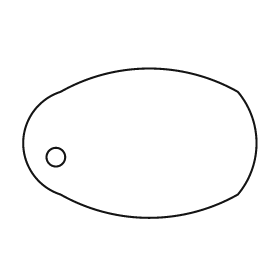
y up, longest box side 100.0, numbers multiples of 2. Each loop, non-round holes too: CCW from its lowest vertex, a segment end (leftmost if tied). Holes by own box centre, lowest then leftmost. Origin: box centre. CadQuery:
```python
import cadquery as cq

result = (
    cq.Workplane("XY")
    .moveTo(-34.0, -22.0)
    .threePointArc((4.0, -32.0), (42.0, -22.0))
    .threePointArc((50.0, 0.0), (42.0, 22.0))
    .threePointArc((4.0, 32.0), (-34.0, 22.0))
    .threePointArc((-50.0, 0.0), (-34.0, -22.0))
    .close()
    .moveTo(-36.0, -6.0)
    .circle(4.0)
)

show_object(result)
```